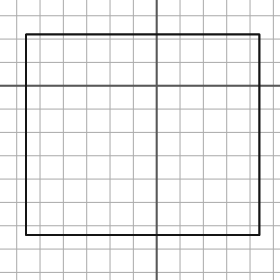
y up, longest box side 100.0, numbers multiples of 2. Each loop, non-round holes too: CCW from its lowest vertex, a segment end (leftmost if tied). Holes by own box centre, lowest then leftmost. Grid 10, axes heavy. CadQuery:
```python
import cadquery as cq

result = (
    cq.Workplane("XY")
    .moveTo(-56.0, -64.0)
    .lineTo(44.0, -64.0)
    .lineTo(44.0, 22.0)
    .lineTo(-56.0, 22.0)
    .close()
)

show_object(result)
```